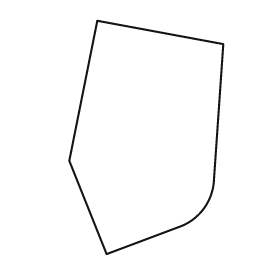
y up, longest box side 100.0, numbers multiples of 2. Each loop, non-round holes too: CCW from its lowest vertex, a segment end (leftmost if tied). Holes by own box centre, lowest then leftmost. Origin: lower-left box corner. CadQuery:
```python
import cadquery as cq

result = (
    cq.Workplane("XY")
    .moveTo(16.0, 0.0)
    .lineTo(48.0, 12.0)
    .threePointArc((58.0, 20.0), (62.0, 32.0))
    .lineTo(66.0, 90.0)
    .lineTo(12.0, 100.0)
    .lineTo(0.0, 40.0)
    .close()
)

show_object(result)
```